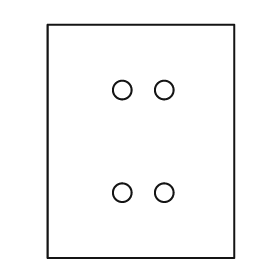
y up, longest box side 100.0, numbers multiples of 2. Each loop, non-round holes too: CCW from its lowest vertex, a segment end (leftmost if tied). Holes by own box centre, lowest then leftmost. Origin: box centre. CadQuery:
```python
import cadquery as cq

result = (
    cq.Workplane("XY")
    .moveTo(-40.0, -50.0)
    .lineTo(40.0, -50.0)
    .lineTo(40.0, 50.0)
    .lineTo(-40.0, 50.0)
    .close()
    .moveTo(-8.0, -22.0)
    .circle(4.0)
    .moveTo(10.0, -22.0)
    .circle(4.0)
    .moveTo(-8.0, 22.0)
    .circle(4.0)
    .moveTo(10.0, 22.0)
    .circle(4.0)
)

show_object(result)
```